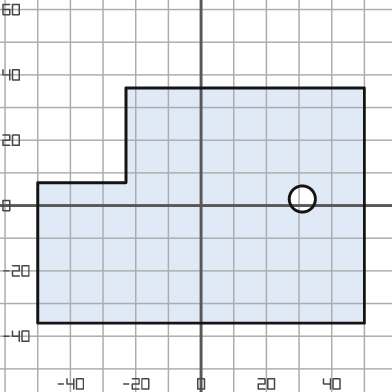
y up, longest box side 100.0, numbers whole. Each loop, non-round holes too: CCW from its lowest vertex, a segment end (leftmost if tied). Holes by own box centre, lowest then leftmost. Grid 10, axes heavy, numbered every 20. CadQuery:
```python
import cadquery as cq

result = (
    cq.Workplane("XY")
    .moveTo(-50.0, -36.0)
    .lineTo(50.0, -36.0)
    .lineTo(50.0, 36.0)
    .lineTo(-23.0, 36.0)
    .lineTo(-23.0, 7.0)
    .lineTo(-50.0, 7.0)
    .close()
    .moveTo(31.0, 2.0)
    .circle(4.0)
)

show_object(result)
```